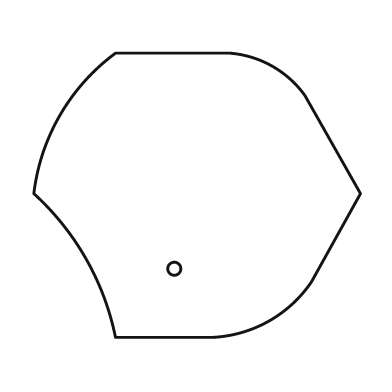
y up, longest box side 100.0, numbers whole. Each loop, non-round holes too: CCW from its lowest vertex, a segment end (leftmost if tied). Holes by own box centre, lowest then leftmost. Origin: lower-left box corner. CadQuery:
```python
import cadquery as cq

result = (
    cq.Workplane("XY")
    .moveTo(25.0, 0.0)
    .lineTo(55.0, 0.0)
    .threePointArc((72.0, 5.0), (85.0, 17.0))
    .lineTo(100.0, 44.0)
    .lineTo(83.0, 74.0)
    .threePointArc((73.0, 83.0), (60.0, 87.0))
    .lineTo(25.0, 87.0)
    .threePointArc((8.0, 68.0), (0.0, 44.0))
    .threePointArc((16.0, 24.0), (25.0, 0.0))
    .close()
    .moveTo(43.0, 21.0)
    .circle(2.0)
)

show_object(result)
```